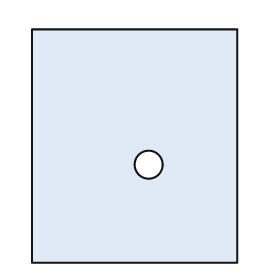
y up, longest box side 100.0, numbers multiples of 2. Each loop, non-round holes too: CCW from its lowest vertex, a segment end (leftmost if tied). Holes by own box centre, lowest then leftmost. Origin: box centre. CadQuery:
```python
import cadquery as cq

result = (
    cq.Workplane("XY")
    .moveTo(-44.0, -50.0)
    .lineTo(44.0, -50.0)
    .lineTo(44.0, 50.0)
    .lineTo(-44.0, 50.0)
    .close()
    .moveTo(6.0, -8.0)
    .circle(6.0)
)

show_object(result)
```